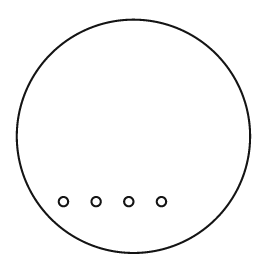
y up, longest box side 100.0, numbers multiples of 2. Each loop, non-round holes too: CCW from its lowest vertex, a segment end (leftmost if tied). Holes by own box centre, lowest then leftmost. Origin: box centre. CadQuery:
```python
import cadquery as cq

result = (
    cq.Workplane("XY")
    .moveTo(0.0, 0.0)
    .circle(50.0)
    .moveTo(-30.0, -28.0)
    .circle(2.0)
    .moveTo(-16.0, -28.0)
    .circle(2.0)
    .moveTo(-2.0, -28.0)
    .circle(2.0)
    .moveTo(12.0, -28.0)
    .circle(2.0)
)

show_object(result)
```